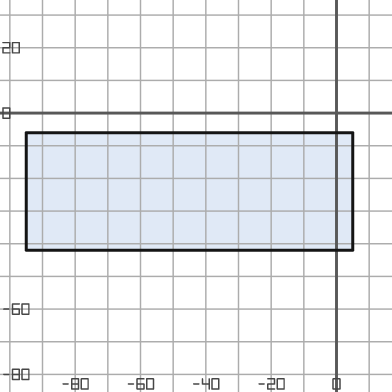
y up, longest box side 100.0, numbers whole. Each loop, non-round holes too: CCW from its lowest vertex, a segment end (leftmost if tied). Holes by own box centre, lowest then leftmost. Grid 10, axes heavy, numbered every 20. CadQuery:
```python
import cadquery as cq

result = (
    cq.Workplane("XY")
    .moveTo(-95.0, -42.0)
    .lineTo(5.0, -42.0)
    .lineTo(5.0, -6.0)
    .lineTo(-95.0, -6.0)
    .close()
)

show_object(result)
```